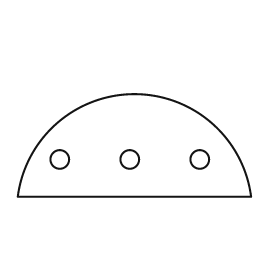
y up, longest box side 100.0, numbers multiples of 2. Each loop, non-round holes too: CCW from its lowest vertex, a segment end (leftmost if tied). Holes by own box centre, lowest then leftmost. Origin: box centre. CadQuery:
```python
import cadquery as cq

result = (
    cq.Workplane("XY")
    .moveTo(-50.0, -22.0)
    .lineTo(50.0, -22.0)
    .threePointArc((0.0, 22.0), (-50.0, -22.0))
    .close()
    .moveTo(-32.0, -6.0)
    .circle(4.0)
    .moveTo(-2.0, -6.0)
    .circle(4.0)
    .moveTo(28.0, -6.0)
    .circle(4.0)
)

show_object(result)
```